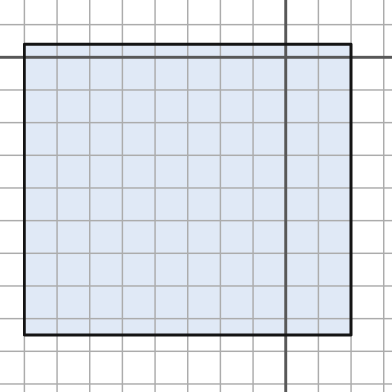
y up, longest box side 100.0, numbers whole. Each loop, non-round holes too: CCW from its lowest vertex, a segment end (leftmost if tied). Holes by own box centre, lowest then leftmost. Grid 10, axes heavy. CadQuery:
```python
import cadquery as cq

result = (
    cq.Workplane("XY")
    .moveTo(-80.0, -85.0)
    .lineTo(20.0, -85.0)
    .lineTo(20.0, 4.0)
    .lineTo(-80.0, 4.0)
    .close()
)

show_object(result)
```